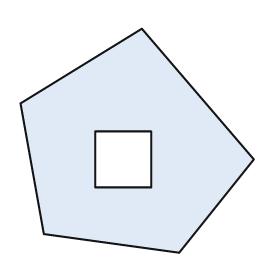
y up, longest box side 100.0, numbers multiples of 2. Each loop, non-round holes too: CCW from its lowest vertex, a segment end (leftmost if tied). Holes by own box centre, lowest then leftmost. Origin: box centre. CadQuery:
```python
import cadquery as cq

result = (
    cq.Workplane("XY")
    .moveTo(18.0, -48.0)
    .lineTo(50.0, -8.0)
    .lineTo(2.0, 48.0)
    .lineTo(-50.0, 16.0)
    .lineTo(-40.0, -40.0)
    .close()
    .moveTo(-18.0, -20.0)
    .lineTo(6.0, -20.0)
    .lineTo(6.0, 4.0)
    .lineTo(-18.0, 4.0)
    .close()
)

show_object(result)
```